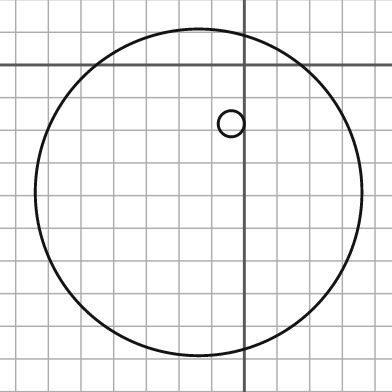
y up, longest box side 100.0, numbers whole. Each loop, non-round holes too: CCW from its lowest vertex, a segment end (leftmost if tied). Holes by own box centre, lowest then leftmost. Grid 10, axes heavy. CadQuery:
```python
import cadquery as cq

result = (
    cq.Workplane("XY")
    .moveTo(-14.0, -39.0)
    .circle(50.0)
    .moveTo(-4.0, -18.0)
    .circle(4.0)
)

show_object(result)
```